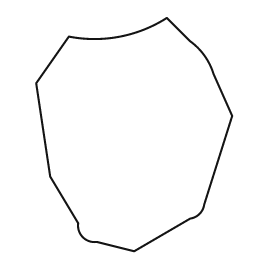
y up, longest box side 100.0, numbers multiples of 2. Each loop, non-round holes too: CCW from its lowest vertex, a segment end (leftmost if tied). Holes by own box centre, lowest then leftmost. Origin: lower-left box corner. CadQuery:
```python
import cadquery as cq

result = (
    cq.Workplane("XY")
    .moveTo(42.0, 0.0)
    .lineTo(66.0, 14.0)
    .threePointArc((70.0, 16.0), (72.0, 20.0))
    .lineTo(84.0, 58.0)
    .lineTo(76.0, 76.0)
    .threePointArc((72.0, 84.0), (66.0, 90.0))
    .lineTo(56.0, 100.0)
    .threePointArc((36.0, 92.0), (14.0, 92.0))
    .lineTo(0.0, 72.0)
    .lineTo(6.0, 32.0)
    .lineTo(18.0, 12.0)
    .threePointArc((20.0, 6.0), (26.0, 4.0))
    .close()
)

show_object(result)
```